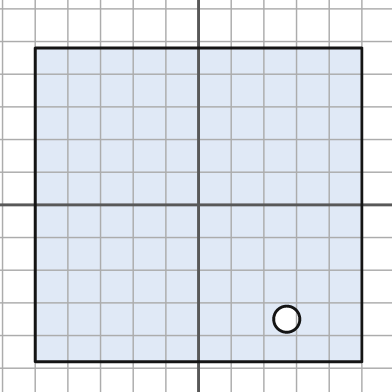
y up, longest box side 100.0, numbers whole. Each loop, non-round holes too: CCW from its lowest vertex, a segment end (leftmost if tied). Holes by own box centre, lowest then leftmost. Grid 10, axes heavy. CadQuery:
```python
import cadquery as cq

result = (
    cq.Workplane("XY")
    .moveTo(-50.0, -48.0)
    .lineTo(50.0, -48.0)
    .lineTo(50.0, 48.0)
    .lineTo(-50.0, 48.0)
    .close()
    .moveTo(27.0, -35.0)
    .circle(4.0)
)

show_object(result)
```